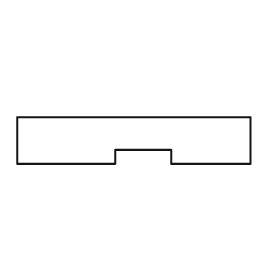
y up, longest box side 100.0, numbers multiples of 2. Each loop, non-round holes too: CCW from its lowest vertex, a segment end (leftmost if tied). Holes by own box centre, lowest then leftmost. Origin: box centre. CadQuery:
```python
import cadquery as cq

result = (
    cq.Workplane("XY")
    .moveTo(-50.0, -10.0)
    .lineTo(-8.0, -10.0)
    .lineTo(-8.0, -4.0)
    .lineTo(16.0, -4.0)
    .lineTo(16.0, -10.0)
    .lineTo(50.0, -10.0)
    .lineTo(50.0, 10.0)
    .lineTo(-50.0, 10.0)
    .close()
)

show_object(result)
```